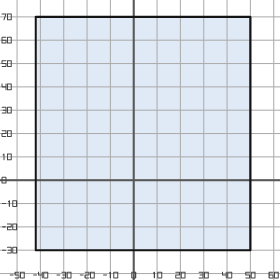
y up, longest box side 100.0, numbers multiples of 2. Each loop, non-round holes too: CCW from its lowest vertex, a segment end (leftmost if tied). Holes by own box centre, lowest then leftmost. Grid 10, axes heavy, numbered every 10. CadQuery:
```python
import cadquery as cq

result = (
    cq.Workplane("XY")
    .moveTo(-42.0, -30.0)
    .lineTo(50.0, -30.0)
    .lineTo(50.0, 70.0)
    .lineTo(-42.0, 70.0)
    .close()
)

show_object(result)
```